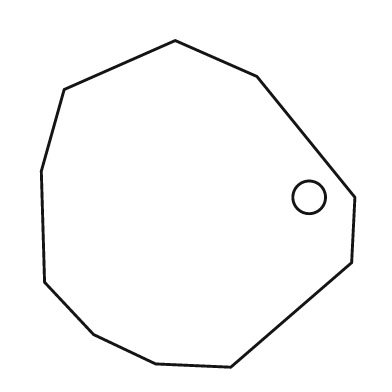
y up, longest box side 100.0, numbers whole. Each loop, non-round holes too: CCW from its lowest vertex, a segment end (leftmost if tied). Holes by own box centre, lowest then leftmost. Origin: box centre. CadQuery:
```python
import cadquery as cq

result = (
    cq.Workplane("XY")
    .moveTo(10.0, -50.0)
    .lineTo(47.0, -18.0)
    .lineTo(48.0, 2.0)
    .lineTo(18.0, 39.0)
    .lineTo(-7.0, 50.0)
    .lineTo(-41.0, 35.0)
    .lineTo(-48.0, 10.0)
    .lineTo(-47.0, -24.0)
    .lineTo(-32.0, -40.0)
    .lineTo(-13.0, -49.0)
    .close()
    .moveTo(34.0, 2.0)
    .circle(5.0)
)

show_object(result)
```